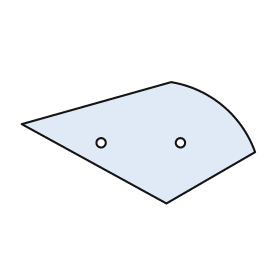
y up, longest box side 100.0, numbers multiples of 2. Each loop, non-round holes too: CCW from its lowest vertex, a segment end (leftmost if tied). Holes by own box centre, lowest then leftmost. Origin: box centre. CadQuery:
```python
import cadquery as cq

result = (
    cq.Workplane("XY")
    .moveTo(12.0, -26.0)
    .lineTo(50.0, -4.0)
    .threePointArc((36.0, 16.0), (14.0, 26.0))
    .lineTo(-50.0, 8.0)
    .close()
    .moveTo(-16.0, 0.0)
    .circle(2.0)
    .moveTo(18.0, 0.0)
    .circle(2.0)
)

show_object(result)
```